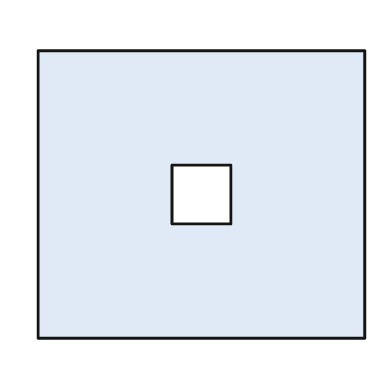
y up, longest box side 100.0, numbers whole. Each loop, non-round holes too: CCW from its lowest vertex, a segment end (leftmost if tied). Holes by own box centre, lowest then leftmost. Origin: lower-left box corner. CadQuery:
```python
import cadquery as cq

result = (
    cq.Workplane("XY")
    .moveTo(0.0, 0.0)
    .lineTo(100.0, 0.0)
    .lineTo(100.0, 88.0)
    .lineTo(0.0, 88.0)
    .close()
    .moveTo(41.0, 35.0)
    .lineTo(59.0, 35.0)
    .lineTo(59.0, 53.0)
    .lineTo(41.0, 53.0)
    .close()
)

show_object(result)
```